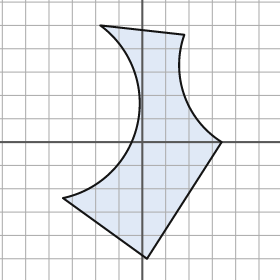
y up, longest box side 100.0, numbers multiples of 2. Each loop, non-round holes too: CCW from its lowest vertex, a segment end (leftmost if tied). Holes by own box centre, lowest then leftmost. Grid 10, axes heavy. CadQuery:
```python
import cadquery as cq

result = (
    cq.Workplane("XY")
    .moveTo(2.0, -50.0)
    .lineTo(34.0, 0.0)
    .threePointArc((18.0, 20.0), (18.0, 46.0))
    .lineTo(-18.0, 50.0)
    .threePointArc((-2.0, 8.0), (-34.0, -24.0))
    .close()
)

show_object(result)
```